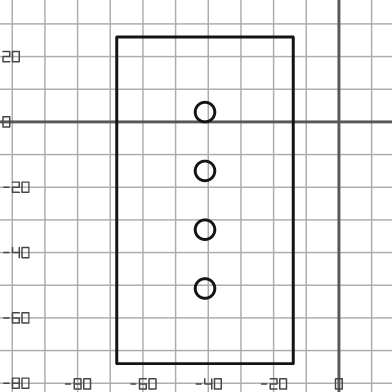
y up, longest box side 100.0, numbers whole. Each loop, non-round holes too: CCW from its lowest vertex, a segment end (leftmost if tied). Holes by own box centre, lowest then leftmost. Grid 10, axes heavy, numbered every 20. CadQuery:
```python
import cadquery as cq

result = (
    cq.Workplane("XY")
    .moveTo(-68.0, -74.0)
    .lineTo(-14.0, -74.0)
    .lineTo(-14.0, 26.0)
    .lineTo(-68.0, 26.0)
    .close()
    .moveTo(-41.0, -51.0)
    .circle(3.0)
    .moveTo(-41.0, -33.0)
    .circle(3.0)
    .moveTo(-41.0, -15.0)
    .circle(3.0)
    .moveTo(-41.0, 3.0)
    .circle(3.0)
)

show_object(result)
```